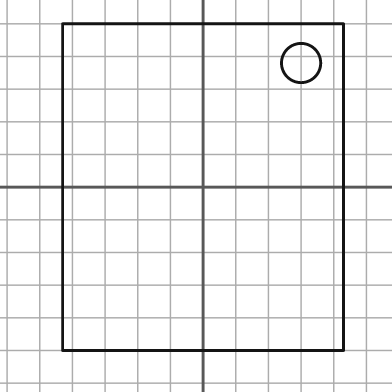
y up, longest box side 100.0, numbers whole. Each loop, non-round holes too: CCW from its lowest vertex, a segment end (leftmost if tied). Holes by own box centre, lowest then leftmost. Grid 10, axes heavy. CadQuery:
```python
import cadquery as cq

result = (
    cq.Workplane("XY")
    .moveTo(-43.0, -50.0)
    .lineTo(43.0, -50.0)
    .lineTo(43.0, 50.0)
    .lineTo(-43.0, 50.0)
    .close()
    .moveTo(30.0, 38.0)
    .circle(6.0)
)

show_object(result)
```